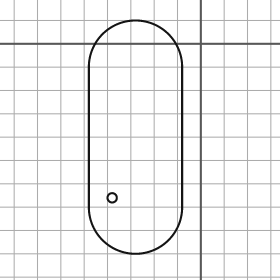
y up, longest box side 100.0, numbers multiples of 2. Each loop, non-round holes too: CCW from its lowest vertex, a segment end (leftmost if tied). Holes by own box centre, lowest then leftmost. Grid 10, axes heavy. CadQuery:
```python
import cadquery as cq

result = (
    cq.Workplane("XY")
    .moveTo(-48.0, -70.0)
    .threePointArc((-28.0, -90.0), (-8.0, -70.0))
    .lineTo(-8.0, -10.0)
    .threePointArc((-28.0, 10.0), (-48.0, -10.0))
    .close()
    .moveTo(-38.0, -66.0)
    .circle(2.0)
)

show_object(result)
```